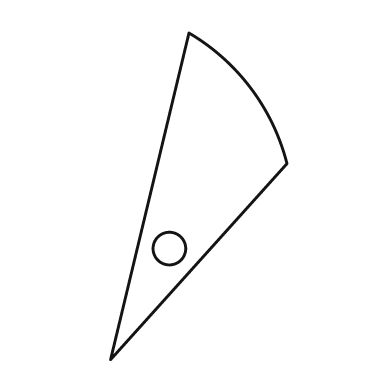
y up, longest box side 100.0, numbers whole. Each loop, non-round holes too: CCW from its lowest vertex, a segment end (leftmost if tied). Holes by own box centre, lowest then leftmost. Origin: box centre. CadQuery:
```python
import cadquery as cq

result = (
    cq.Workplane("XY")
    .moveTo(-27.0, -50.0)
    .lineTo(27.0, 10.0)
    .threePointArc((16.0, 33.0), (-3.0, 50.0))
    .close()
    .moveTo(-9.0, -16.0)
    .circle(5.0)
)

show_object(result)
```